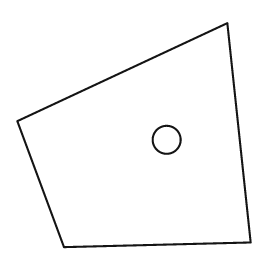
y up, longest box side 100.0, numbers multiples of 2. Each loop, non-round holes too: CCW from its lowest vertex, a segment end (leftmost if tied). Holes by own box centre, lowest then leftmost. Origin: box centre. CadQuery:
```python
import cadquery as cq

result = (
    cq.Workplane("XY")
    .moveTo(-30.0, -48.0)
    .lineTo(50.0, -46.0)
    .lineTo(40.0, 48.0)
    .lineTo(-50.0, 6.0)
    .close()
    .moveTo(14.0, -2.0)
    .circle(6.0)
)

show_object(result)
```